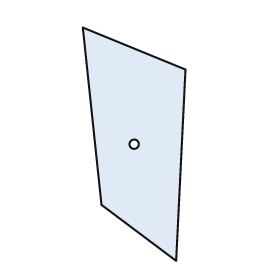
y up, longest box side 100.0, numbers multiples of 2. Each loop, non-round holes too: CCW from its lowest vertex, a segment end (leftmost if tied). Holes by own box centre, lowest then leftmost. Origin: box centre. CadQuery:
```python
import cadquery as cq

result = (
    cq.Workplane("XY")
    .moveTo(18.0, -50.0)
    .lineTo(22.0, 32.0)
    .lineTo(-22.0, 50.0)
    .lineTo(-14.0, -26.0)
    .close()
    .moveTo(0.0, 0.0)
    .circle(2.0)
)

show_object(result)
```